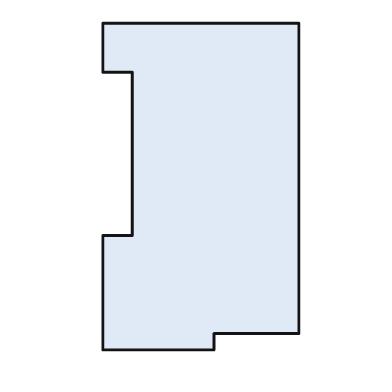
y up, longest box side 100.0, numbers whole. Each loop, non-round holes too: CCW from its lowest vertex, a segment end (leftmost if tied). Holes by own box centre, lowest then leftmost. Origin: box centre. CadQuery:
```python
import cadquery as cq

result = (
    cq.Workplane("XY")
    .moveTo(-30.0, -50.0)
    .lineTo(4.0, -50.0)
    .lineTo(4.0, -45.0)
    .lineTo(30.0, -45.0)
    .lineTo(30.0, 50.0)
    .lineTo(-30.0, 50.0)
    .lineTo(-30.0, 35.0)
    .lineTo(-21.0, 35.0)
    .lineTo(-21.0, -15.0)
    .lineTo(-30.0, -15.0)
    .close()
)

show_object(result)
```